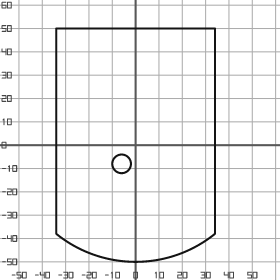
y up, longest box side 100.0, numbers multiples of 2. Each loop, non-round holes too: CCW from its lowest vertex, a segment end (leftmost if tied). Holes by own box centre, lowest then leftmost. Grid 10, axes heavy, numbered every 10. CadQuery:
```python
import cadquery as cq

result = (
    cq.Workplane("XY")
    .moveTo(-34.0, -38.0)
    .threePointArc((0.0, -50.0), (34.0, -38.0))
    .lineTo(34.0, 50.0)
    .lineTo(-34.0, 50.0)
    .close()
    .moveTo(-6.0, -8.0)
    .circle(4.0)
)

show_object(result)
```